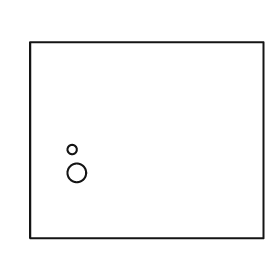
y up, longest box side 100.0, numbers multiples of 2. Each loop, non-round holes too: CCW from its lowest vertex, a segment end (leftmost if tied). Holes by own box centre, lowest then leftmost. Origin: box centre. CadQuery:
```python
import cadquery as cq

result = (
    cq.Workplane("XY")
    .moveTo(-50.0, -42.0)
    .lineTo(50.0, -42.0)
    .lineTo(50.0, 42.0)
    .lineTo(-50.0, 42.0)
    .close()
    .moveTo(-30.0, -14.0)
    .circle(4.0)
    .moveTo(-32.0, -4.0)
    .circle(2.0)
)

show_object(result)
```